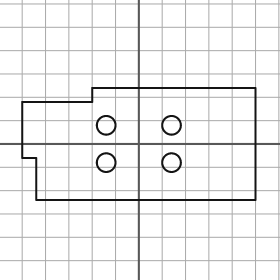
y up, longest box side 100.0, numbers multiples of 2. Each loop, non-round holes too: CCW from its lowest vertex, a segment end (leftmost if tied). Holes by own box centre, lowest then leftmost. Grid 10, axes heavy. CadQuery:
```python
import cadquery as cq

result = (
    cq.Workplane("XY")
    .moveTo(-44.0, -24.0)
    .lineTo(50.0, -24.0)
    .lineTo(50.0, 24.0)
    .lineTo(-20.0, 24.0)
    .lineTo(-20.0, 18.0)
    .lineTo(-50.0, 18.0)
    .lineTo(-50.0, -6.0)
    .lineTo(-44.0, -6.0)
    .close()
    .moveTo(-14.0, -8.0)
    .circle(4.0)
    .moveTo(14.0, -8.0)
    .circle(4.0)
    .moveTo(-14.0, 8.0)
    .circle(4.0)
    .moveTo(14.0, 8.0)
    .circle(4.0)
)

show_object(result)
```